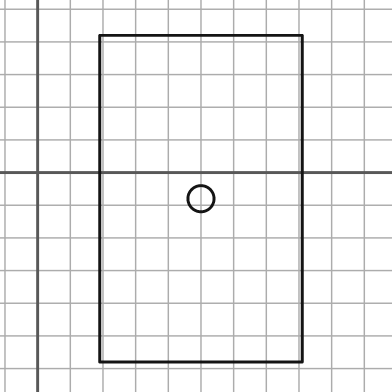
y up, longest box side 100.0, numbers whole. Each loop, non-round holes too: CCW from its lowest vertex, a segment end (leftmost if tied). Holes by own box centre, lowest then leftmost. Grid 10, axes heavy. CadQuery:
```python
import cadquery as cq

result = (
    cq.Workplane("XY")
    .moveTo(19.0, -58.0)
    .lineTo(81.0, -58.0)
    .lineTo(81.0, 42.0)
    .lineTo(19.0, 42.0)
    .close()
    .moveTo(50.0, -8.0)
    .circle(4.0)
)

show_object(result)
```